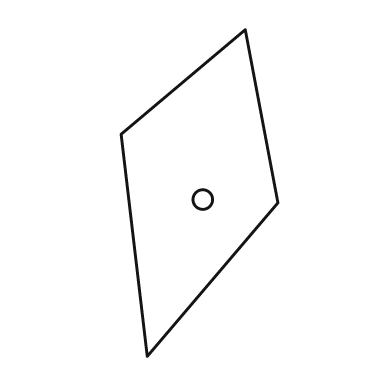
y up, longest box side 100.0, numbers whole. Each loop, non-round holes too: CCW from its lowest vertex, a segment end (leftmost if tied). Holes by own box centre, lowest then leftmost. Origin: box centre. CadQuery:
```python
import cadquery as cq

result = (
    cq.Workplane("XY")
    .moveTo(-16.0, -50.0)
    .lineTo(24.0, -3.0)
    .lineTo(14.0, 50.0)
    .lineTo(-24.0, 18.0)
    .close()
    .moveTo(1.0, -2.0)
    .circle(3.0)
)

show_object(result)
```